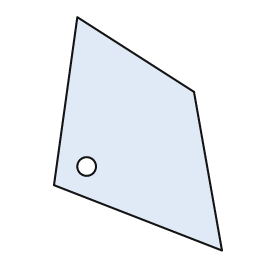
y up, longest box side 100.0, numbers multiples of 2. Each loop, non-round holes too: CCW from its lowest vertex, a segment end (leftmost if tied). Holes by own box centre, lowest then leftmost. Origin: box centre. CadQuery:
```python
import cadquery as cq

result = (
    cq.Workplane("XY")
    .moveTo(36.0, -50.0)
    .lineTo(24.0, 18.0)
    .lineTo(-26.0, 50.0)
    .lineTo(-36.0, -22.0)
    .close()
    .moveTo(-22.0, -14.0)
    .circle(4.0)
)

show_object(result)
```